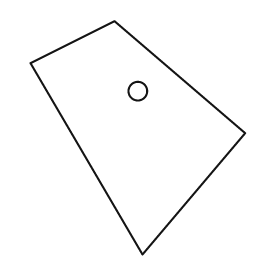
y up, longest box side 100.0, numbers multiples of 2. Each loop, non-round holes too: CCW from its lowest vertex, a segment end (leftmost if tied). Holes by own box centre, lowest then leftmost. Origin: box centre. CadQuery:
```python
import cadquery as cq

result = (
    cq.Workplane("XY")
    .moveTo(2.0, -50.0)
    .lineTo(46.0, 2.0)
    .lineTo(-10.0, 50.0)
    .lineTo(-46.0, 32.0)
    .close()
    .moveTo(0.0, 20.0)
    .circle(4.0)
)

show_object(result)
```